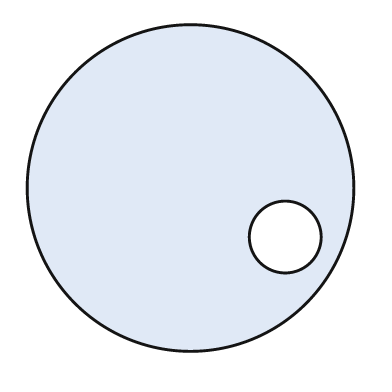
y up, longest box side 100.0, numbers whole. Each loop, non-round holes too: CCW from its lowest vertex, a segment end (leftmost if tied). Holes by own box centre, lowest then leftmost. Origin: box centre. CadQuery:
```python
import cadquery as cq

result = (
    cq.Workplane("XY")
    .moveTo(0.0, 0.0)
    .circle(50.0)
    .moveTo(29.0, -15.0)
    .circle(11.0)
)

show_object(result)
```